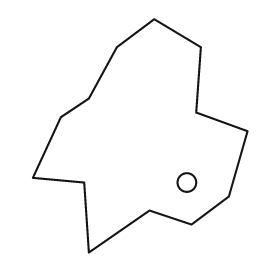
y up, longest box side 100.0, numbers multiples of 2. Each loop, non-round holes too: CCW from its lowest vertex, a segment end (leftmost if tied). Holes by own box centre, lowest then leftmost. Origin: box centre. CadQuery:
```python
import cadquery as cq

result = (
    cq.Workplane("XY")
    .moveTo(-22.0, -50.0)
    .lineTo(4.0, -32.0)
    .lineTo(22.0, -38.0)
    .lineTo(38.0, -26.0)
    .lineTo(46.0, 2.0)
    .lineTo(24.0, 10.0)
    .lineTo(26.0, 38.0)
    .lineTo(6.0, 50.0)
    .lineTo(-10.0, 38.0)
    .lineTo(-22.0, 16.0)
    .lineTo(-34.0, 8.0)
    .lineTo(-46.0, -18.0)
    .lineTo(-24.0, -20.0)
    .close()
    .moveTo(20.0, -20.0)
    .circle(4.0)
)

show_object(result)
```